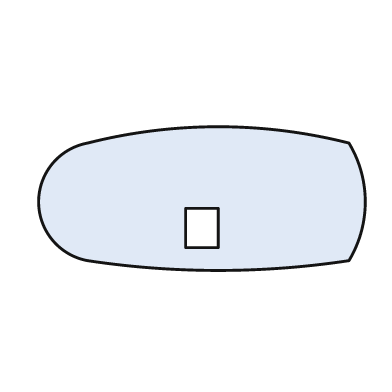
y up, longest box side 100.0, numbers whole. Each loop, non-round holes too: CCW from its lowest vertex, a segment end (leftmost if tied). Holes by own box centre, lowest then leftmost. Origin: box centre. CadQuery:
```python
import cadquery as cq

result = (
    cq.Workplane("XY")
    .moveTo(-35.0, -19.0)
    .threePointArc((5.0, -22.0), (45.0, -19.0))
    .threePointArc((50.0, -1.0), (45.0, 17.0))
    .threePointArc((5.0, 22.0), (-35.0, 17.0))
    .threePointArc((-50.0, -1.0), (-35.0, -19.0))
    .close()
    .moveTo(-5.0, -15.0)
    .lineTo(5.0, -15.0)
    .lineTo(5.0, -3.0)
    .lineTo(-5.0, -3.0)
    .close()
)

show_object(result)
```